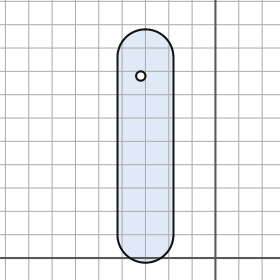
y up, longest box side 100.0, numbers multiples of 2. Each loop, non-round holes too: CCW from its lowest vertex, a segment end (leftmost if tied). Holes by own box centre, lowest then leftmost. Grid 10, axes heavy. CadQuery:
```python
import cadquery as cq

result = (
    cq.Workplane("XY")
    .moveTo(-42.0, 10.0)
    .threePointArc((-30.0, -2.0), (-18.0, 10.0))
    .lineTo(-18.0, 86.0)
    .threePointArc((-30.0, 98.0), (-42.0, 86.0))
    .close()
    .moveTo(-32.0, 78.0)
    .circle(2.0)
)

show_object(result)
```